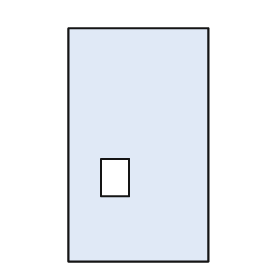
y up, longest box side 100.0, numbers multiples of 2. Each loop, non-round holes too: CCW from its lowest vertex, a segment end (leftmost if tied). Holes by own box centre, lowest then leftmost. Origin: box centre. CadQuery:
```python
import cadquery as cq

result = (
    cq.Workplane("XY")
    .moveTo(-30.0, -50.0)
    .lineTo(30.0, -50.0)
    .lineTo(30.0, 50.0)
    .lineTo(-30.0, 50.0)
    .close()
    .moveTo(-16.0, -22.0)
    .lineTo(-4.0, -22.0)
    .lineTo(-4.0, -6.0)
    .lineTo(-16.0, -6.0)
    .close()
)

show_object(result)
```